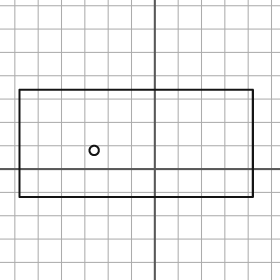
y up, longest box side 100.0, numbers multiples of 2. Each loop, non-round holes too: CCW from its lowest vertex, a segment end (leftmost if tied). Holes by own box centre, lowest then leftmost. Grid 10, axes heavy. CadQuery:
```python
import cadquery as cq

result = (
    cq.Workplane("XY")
    .moveTo(-58.0, -12.0)
    .lineTo(42.0, -12.0)
    .lineTo(42.0, 34.0)
    .lineTo(-58.0, 34.0)
    .close()
    .moveTo(-26.0, 8.0)
    .circle(2.0)
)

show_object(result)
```